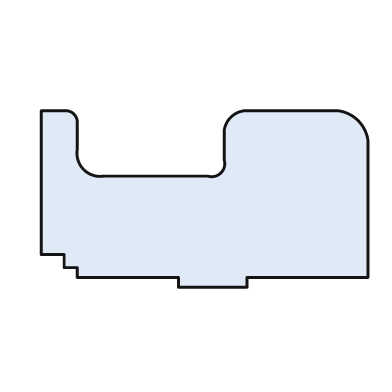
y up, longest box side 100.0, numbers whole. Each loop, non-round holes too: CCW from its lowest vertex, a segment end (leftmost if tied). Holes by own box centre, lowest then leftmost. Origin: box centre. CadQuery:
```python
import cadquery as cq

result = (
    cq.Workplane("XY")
    .moveTo(-8.0, -27.0)
    .lineTo(13.0, -27.0)
    .lineTo(13.0, -24.0)
    .lineTo(50.0, -24.0)
    .lineTo(50.0, 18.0)
    .threePointArc((47.0, 24.0), (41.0, 27.0))
    .lineTo(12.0, 27.0)
    .threePointArc((8.0, 25.0), (6.0, 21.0))
    .lineTo(6.0, 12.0)
    .threePointArc((5.0, 8.0), (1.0, 7.0))
    .lineTo(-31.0, 7.0)
    .threePointArc((-37.0, 9.0), (-39.0, 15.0))
    .lineTo(-39.0, 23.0)
    .threePointArc((-40.0, 26.0), (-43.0, 27.0))
    .lineTo(-50.0, 27.0)
    .lineTo(-50.0, -17.0)
    .lineTo(-43.0, -17.0)
    .lineTo(-43.0, -21.0)
    .lineTo(-39.0, -21.0)
    .lineTo(-39.0, -24.0)
    .lineTo(-8.0, -24.0)
    .close()
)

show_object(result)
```